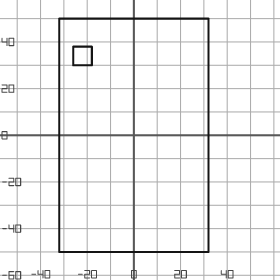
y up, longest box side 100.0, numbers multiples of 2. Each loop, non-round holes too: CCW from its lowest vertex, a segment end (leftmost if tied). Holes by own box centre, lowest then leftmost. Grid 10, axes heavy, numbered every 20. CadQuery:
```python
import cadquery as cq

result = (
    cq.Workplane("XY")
    .moveTo(-32.0, -50.0)
    .lineTo(32.0, -50.0)
    .lineTo(32.0, 50.0)
    .lineTo(-32.0, 50.0)
    .close()
    .moveTo(-26.0, 30.0)
    .lineTo(-18.0, 30.0)
    .lineTo(-18.0, 38.0)
    .lineTo(-26.0, 38.0)
    .close()
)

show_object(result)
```